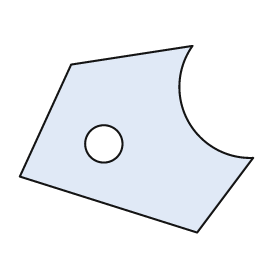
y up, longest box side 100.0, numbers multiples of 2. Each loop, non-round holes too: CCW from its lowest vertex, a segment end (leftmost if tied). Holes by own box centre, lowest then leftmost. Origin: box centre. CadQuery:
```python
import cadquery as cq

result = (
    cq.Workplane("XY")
    .moveTo(26.0, -40.0)
    .lineTo(50.0, -8.0)
    .threePointArc((22.0, 8.0), (24.0, 40.0))
    .lineTo(-28.0, 32.0)
    .lineTo(-50.0, -16.0)
    .close()
    .moveTo(-14.0, -2.0)
    .circle(8.0)
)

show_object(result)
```